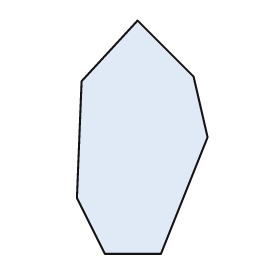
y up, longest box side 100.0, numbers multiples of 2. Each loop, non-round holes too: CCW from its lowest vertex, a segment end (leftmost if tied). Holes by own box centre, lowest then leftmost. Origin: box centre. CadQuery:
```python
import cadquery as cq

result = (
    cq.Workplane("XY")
    .moveTo(-16.0, -50.0)
    .lineTo(8.0, -50.0)
    .lineTo(28.0, 0.0)
    .lineTo(22.0, 26.0)
    .lineTo(-2.0, 50.0)
    .lineTo(-26.0, 24.0)
    .lineTo(-28.0, -26.0)
    .close()
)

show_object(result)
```